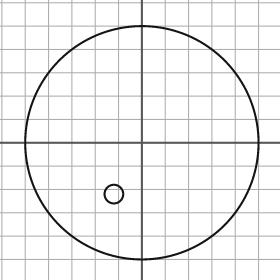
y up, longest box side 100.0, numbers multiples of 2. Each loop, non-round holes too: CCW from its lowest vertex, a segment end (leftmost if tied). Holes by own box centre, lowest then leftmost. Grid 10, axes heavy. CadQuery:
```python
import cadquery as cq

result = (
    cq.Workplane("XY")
    .moveTo(0.0, 0.0)
    .circle(50.0)
    .moveTo(-12.0, -22.0)
    .circle(4.0)
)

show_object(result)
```